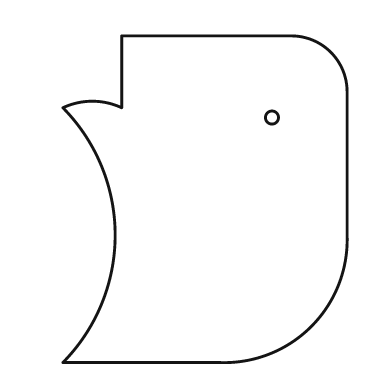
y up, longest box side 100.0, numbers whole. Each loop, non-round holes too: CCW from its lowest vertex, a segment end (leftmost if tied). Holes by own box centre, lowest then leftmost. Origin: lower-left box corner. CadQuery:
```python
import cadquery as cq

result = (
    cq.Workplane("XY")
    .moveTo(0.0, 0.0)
    .lineTo(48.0, 0.0)
    .threePointArc((76.0, 11.0), (87.0, 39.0))
    .lineTo(87.0, 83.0)
    .threePointArc((82.0, 95.0), (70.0, 100.0))
    .lineTo(18.0, 100.0)
    .lineTo(18.0, 78.0)
    .threePointArc((9.0, 80.0), (0.0, 78.0))
    .threePointArc((16.0, 39.0), (0.0, 0.0))
    .close()
    .moveTo(64.0, 75.0)
    .circle(2.0)
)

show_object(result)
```